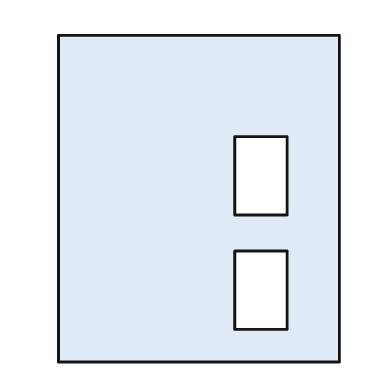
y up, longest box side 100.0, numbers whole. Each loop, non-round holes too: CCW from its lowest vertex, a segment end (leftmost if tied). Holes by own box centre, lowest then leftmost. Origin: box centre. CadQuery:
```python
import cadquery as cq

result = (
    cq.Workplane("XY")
    .moveTo(-43.0, -50.0)
    .lineTo(43.0, -50.0)
    .lineTo(43.0, 50.0)
    .lineTo(-43.0, 50.0)
    .close()
    .moveTo(11.0, -40.0)
    .lineTo(27.0, -40.0)
    .lineTo(27.0, -16.0)
    .lineTo(11.0, -16.0)
    .close()
    .moveTo(11.0, -5.0)
    .lineTo(27.0, -5.0)
    .lineTo(27.0, 19.0)
    .lineTo(11.0, 19.0)
    .close()
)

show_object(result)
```